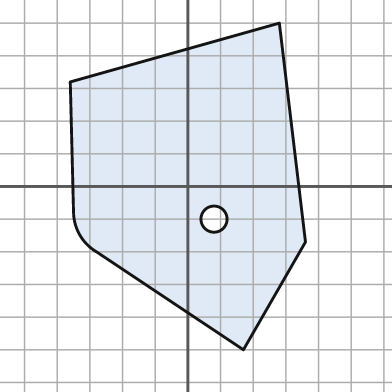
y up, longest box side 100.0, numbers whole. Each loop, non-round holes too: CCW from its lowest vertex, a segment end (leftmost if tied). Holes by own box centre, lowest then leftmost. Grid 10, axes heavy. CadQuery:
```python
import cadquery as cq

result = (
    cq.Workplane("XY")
    .moveTo(17.0, -50.0)
    .lineTo(36.0, -17.0)
    .lineTo(28.0, 50.0)
    .lineTo(-36.0, 32.0)
    .lineTo(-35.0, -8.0)
    .threePointArc((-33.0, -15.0), (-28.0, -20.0))
    .close()
    .moveTo(8.0, -10.0)
    .circle(4.0)
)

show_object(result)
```